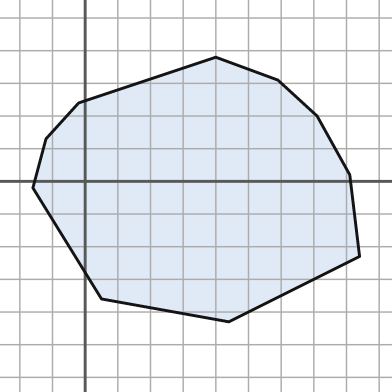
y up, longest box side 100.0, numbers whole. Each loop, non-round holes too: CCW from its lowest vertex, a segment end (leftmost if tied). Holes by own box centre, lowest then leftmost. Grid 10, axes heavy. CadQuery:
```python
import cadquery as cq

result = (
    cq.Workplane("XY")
    .moveTo(44.0, -43.0)
    .lineTo(84.0, -23.0)
    .lineTo(81.0, 2.0)
    .lineTo(71.0, 20.0)
    .lineTo(59.0, 31.0)
    .lineTo(40.0, 38.0)
    .lineTo(-2.0, 24.0)
    .lineTo(-12.0, 13.0)
    .lineTo(-16.0, -2.0)
    .lineTo(5.0, -36.0)
    .close()
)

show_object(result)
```